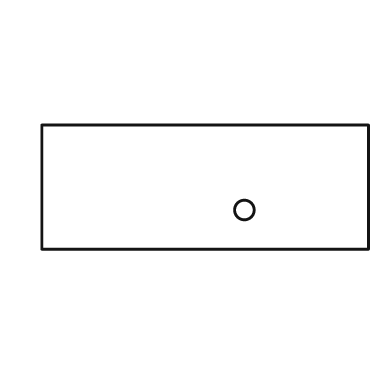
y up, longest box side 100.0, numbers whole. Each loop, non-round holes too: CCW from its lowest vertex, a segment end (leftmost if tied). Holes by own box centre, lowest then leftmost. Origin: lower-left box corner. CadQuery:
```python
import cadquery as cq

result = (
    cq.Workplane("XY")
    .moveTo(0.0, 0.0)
    .lineTo(100.0, 0.0)
    .lineTo(100.0, 38.0)
    .lineTo(0.0, 38.0)
    .close()
    .moveTo(62.0, 12.0)
    .circle(3.0)
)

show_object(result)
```